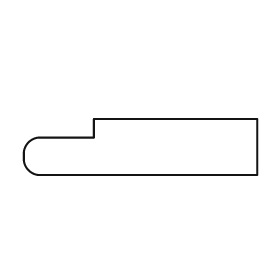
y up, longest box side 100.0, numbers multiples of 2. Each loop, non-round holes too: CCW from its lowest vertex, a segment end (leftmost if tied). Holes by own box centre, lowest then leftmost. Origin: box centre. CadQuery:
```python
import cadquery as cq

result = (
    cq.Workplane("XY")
    .moveTo(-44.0, -12.0)
    .lineTo(50.0, -12.0)
    .lineTo(50.0, 12.0)
    .lineTo(-20.0, 12.0)
    .lineTo(-20.0, 4.0)
    .lineTo(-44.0, 4.0)
    .threePointArc((-48.0, 2.0), (-50.0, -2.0))
    .lineTo(-50.0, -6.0)
    .threePointArc((-48.0, -10.0), (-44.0, -12.0))
    .close()
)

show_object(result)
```